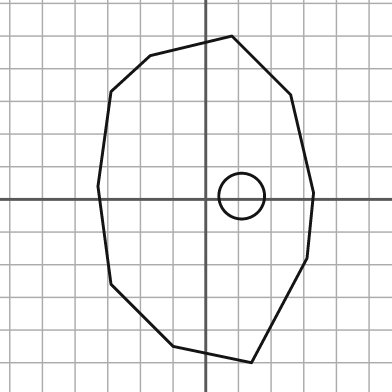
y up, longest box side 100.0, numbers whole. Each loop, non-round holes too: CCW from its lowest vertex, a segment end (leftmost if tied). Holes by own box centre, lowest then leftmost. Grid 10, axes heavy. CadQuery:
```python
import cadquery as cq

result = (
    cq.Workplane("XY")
    .moveTo(14.0, -50.0)
    .lineTo(31.0, -18.0)
    .lineTo(33.0, 2.0)
    .lineTo(26.0, 32.0)
    .lineTo(8.0, 50.0)
    .lineTo(-17.0, 44.0)
    .lineTo(-29.0, 33.0)
    .lineTo(-33.0, 4.0)
    .lineTo(-29.0, -26.0)
    .lineTo(-10.0, -45.0)
    .close()
    .moveTo(11.0, 1.0)
    .circle(7.0)
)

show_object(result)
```